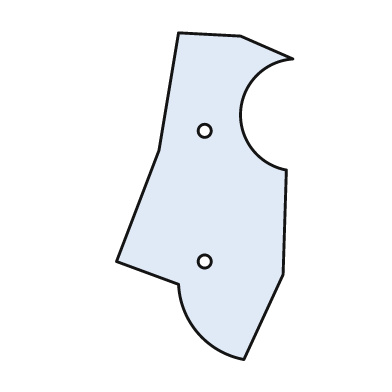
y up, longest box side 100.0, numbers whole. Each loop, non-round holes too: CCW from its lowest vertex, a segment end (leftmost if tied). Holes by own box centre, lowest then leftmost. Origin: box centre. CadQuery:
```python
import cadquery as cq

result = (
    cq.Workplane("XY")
    .moveTo(12.0, -50.0)
    .lineTo(24.0, -24.0)
    .lineTo(25.0, 8.0)
    .threePointArc((11.0, 26.0), (27.0, 42.0))
    .lineTo(11.0, 49.0)
    .lineTo(-8.0, 50.0)
    .lineTo(-14.0, 14.0)
    .lineTo(-27.0, -20.0)
    .lineTo(-8.0, -27.0)
    .threePointArc((-2.0, -42.0), (12.0, -50.0))
    .close()
    .moveTo(0.0, -20.0)
    .circle(2.0)
    .moveTo(0.0, 20.0)
    .circle(2.0)
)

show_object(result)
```